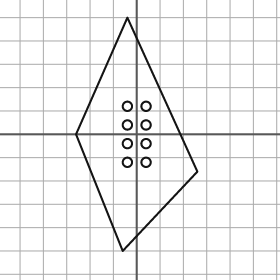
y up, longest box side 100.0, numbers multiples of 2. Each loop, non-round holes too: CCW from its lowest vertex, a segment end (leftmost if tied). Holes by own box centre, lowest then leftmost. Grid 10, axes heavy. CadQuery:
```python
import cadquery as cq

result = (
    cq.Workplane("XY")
    .moveTo(-6.0, -50.0)
    .lineTo(26.0, -16.0)
    .lineTo(-4.0, 50.0)
    .lineTo(-26.0, 0.0)
    .close()
    .moveTo(-4.0, -12.0)
    .circle(2.0)
    .moveTo(4.0, -12.0)
    .circle(2.0)
    .moveTo(-4.0, -4.0)
    .circle(2.0)
    .moveTo(4.0, -4.0)
    .circle(2.0)
    .moveTo(-4.0, 4.0)
    .circle(2.0)
    .moveTo(4.0, 4.0)
    .circle(2.0)
    .moveTo(-4.0, 12.0)
    .circle(2.0)
    .moveTo(4.0, 12.0)
    .circle(2.0)
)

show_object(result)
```